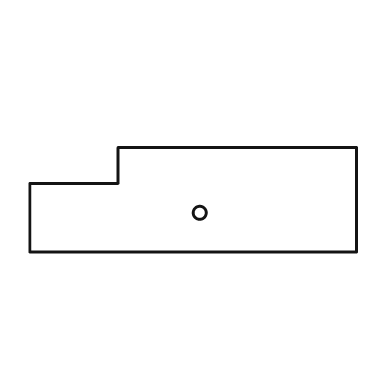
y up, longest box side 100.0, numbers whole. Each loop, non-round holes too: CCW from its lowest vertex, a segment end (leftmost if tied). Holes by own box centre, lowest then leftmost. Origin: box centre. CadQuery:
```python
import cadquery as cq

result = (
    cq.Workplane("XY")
    .moveTo(-50.0, -16.0)
    .lineTo(50.0, -16.0)
    .lineTo(50.0, 16.0)
    .lineTo(-23.0, 16.0)
    .lineTo(-23.0, 5.0)
    .lineTo(-50.0, 5.0)
    .close()
    .moveTo(2.0, -4.0)
    .circle(2.0)
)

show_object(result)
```